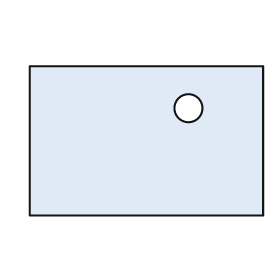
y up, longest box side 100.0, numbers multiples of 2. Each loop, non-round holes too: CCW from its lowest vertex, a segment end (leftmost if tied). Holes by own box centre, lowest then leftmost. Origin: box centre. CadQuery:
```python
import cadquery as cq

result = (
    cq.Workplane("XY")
    .moveTo(-50.0, -32.0)
    .lineTo(50.0, -32.0)
    .lineTo(50.0, 32.0)
    .lineTo(-50.0, 32.0)
    .close()
    .moveTo(18.0, 14.0)
    .circle(6.0)
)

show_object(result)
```